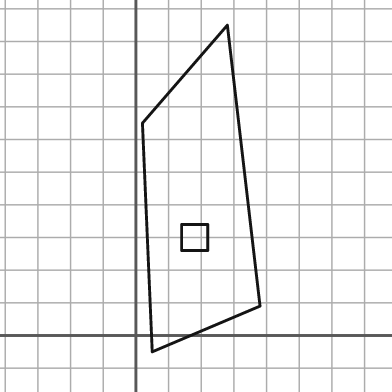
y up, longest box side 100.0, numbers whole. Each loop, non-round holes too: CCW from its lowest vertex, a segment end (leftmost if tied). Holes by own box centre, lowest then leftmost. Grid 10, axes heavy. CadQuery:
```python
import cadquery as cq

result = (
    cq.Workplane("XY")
    .moveTo(5.0, -5.0)
    .lineTo(38.0, 9.0)
    .lineTo(28.0, 95.0)
    .lineTo(2.0, 65.0)
    .close()
    .moveTo(14.0, 26.0)
    .lineTo(22.0, 26.0)
    .lineTo(22.0, 34.0)
    .lineTo(14.0, 34.0)
    .close()
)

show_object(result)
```